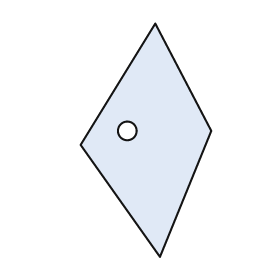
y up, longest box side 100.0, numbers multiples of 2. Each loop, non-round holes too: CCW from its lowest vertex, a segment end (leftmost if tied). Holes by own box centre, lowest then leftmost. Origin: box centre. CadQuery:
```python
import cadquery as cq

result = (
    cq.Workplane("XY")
    .moveTo(6.0, -50.0)
    .lineTo(28.0, 4.0)
    .lineTo(4.0, 50.0)
    .lineTo(-28.0, -2.0)
    .close()
    .moveTo(-8.0, 4.0)
    .circle(4.0)
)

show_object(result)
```